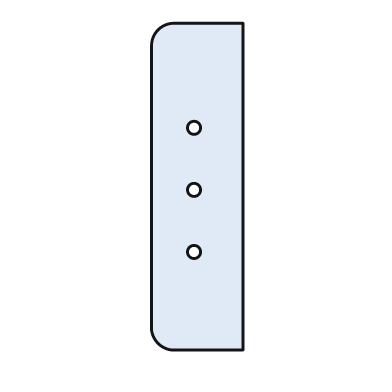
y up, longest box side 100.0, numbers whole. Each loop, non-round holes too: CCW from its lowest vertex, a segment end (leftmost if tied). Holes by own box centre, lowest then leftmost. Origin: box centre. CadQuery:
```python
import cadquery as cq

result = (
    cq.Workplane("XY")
    .moveTo(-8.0, -50.0)
    .lineTo(14.0, -50.0)
    .lineTo(14.0, 50.0)
    .lineTo(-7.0, 50.0)
    .threePointArc((-12.0, 48.0), (-14.0, 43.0))
    .lineTo(-14.0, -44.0)
    .threePointArc((-12.0, -48.0), (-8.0, -50.0))
    .close()
    .moveTo(-1.0, -20.0)
    .circle(2.0)
    .moveTo(-1.0, -1.0)
    .circle(2.0)
    .moveTo(-1.0, 18.0)
    .circle(2.0)
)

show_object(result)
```